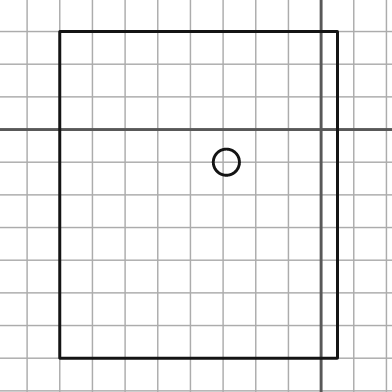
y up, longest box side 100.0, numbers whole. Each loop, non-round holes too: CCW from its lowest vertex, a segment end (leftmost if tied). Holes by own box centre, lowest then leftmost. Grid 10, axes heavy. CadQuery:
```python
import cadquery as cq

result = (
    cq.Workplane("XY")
    .moveTo(-80.0, -70.0)
    .lineTo(5.0, -70.0)
    .lineTo(5.0, 30.0)
    .lineTo(-80.0, 30.0)
    .close()
    .moveTo(-29.0, -10.0)
    .circle(4.0)
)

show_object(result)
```